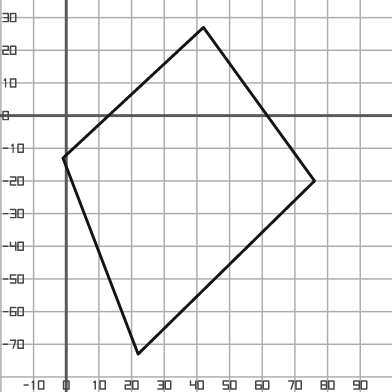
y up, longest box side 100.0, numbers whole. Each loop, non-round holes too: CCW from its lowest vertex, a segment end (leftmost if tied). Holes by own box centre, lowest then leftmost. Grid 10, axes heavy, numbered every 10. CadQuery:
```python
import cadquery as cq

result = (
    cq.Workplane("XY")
    .moveTo(22.0, -73.0)
    .lineTo(76.0, -20.0)
    .lineTo(42.0, 27.0)
    .lineTo(-1.0, -13.0)
    .close()
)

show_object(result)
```